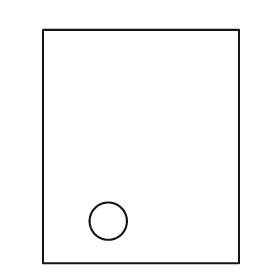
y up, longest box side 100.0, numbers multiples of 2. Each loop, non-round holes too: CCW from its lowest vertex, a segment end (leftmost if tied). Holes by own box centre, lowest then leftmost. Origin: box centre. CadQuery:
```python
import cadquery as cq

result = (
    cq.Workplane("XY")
    .moveTo(-42.0, -50.0)
    .lineTo(42.0, -50.0)
    .lineTo(42.0, 50.0)
    .lineTo(-42.0, 50.0)
    .close()
    .moveTo(-14.0, -32.0)
    .circle(8.0)
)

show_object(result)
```